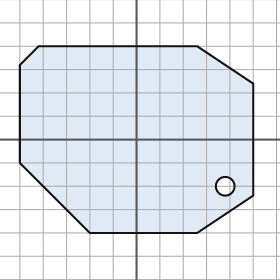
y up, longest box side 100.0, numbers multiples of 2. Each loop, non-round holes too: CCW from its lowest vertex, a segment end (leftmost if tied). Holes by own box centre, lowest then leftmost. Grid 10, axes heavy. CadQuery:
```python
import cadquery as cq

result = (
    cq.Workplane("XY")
    .moveTo(-20.0, -40.0)
    .lineTo(26.0, -40.0)
    .lineTo(50.0, -24.0)
    .lineTo(50.0, 24.0)
    .lineTo(26.0, 40.0)
    .lineTo(-42.0, 40.0)
    .lineTo(-50.0, 32.0)
    .lineTo(-50.0, -10.0)
    .close()
    .moveTo(38.0, -20.0)
    .circle(4.0)
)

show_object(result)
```